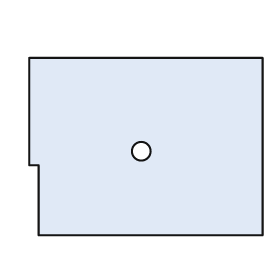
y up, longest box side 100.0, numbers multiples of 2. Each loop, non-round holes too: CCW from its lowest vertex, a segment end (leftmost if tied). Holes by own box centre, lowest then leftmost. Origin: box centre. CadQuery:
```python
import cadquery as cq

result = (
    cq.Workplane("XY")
    .moveTo(-46.0, -38.0)
    .lineTo(50.0, -38.0)
    .lineTo(50.0, 38.0)
    .lineTo(-50.0, 38.0)
    .lineTo(-50.0, -8.0)
    .lineTo(-46.0, -8.0)
    .close()
    .moveTo(-2.0, -2.0)
    .circle(4.0)
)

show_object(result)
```